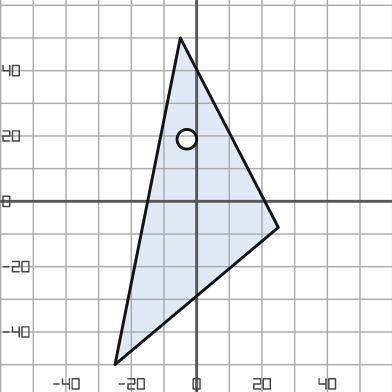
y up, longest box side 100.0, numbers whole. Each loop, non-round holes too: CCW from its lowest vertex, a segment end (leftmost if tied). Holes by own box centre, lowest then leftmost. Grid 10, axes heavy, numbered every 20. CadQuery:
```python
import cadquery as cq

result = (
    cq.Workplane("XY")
    .moveTo(-25.0, -50.0)
    .lineTo(25.0, -8.0)
    .lineTo(-5.0, 50.0)
    .close()
    .moveTo(-3.0, 19.0)
    .circle(3.0)
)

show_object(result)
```